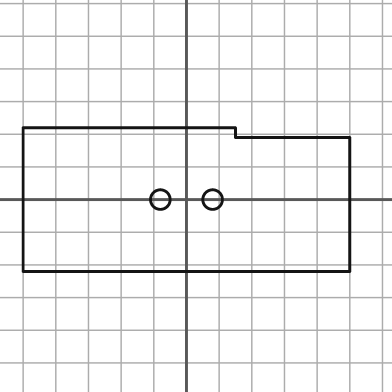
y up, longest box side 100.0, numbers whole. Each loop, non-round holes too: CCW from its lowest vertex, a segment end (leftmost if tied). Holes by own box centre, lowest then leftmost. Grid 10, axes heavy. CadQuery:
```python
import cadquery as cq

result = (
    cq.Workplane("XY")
    .moveTo(-50.0, -22.0)
    .lineTo(50.0, -22.0)
    .lineTo(50.0, 19.0)
    .lineTo(15.0, 19.0)
    .lineTo(15.0, 22.0)
    .lineTo(-50.0, 22.0)
    .close()
    .moveTo(-8.0, 0.0)
    .circle(3.0)
    .moveTo(8.0, 0.0)
    .circle(3.0)
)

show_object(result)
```